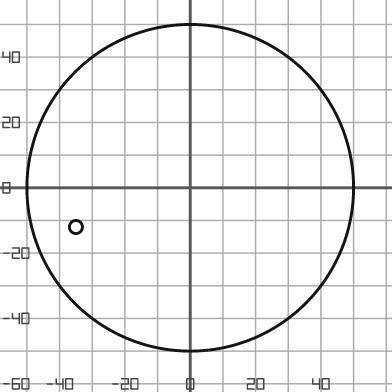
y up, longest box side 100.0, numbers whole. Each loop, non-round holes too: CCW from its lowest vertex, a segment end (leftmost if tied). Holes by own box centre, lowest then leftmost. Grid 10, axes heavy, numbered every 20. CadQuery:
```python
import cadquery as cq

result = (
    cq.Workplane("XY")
    .moveTo(0.0, 0.0)
    .circle(50.0)
    .moveTo(-35.0, -12.0)
    .circle(2.0)
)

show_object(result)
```